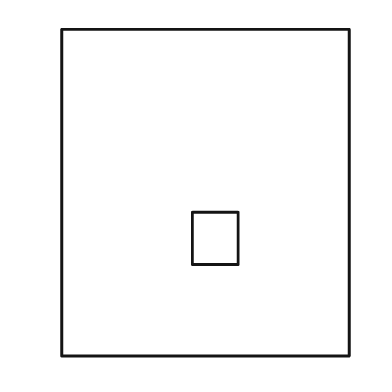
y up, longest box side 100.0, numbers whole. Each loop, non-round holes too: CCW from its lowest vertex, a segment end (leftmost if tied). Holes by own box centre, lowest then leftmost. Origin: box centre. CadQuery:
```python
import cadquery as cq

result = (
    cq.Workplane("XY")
    .moveTo(-44.0, -50.0)
    .lineTo(44.0, -50.0)
    .lineTo(44.0, 50.0)
    .lineTo(-44.0, 50.0)
    .close()
    .moveTo(-4.0, -22.0)
    .lineTo(10.0, -22.0)
    .lineTo(10.0, -6.0)
    .lineTo(-4.0, -6.0)
    .close()
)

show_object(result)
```